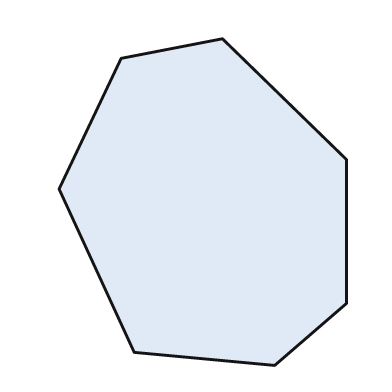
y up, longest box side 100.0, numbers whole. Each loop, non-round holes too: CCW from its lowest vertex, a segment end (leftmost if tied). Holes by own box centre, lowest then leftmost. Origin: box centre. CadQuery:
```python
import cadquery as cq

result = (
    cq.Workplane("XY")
    .moveTo(22.0, -50.0)
    .lineTo(44.0, -31.0)
    .lineTo(44.0, 13.0)
    .lineTo(6.0, 50.0)
    .lineTo(-25.0, 44.0)
    .lineTo(-44.0, 4.0)
    .lineTo(-21.0, -46.0)
    .close()
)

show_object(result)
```